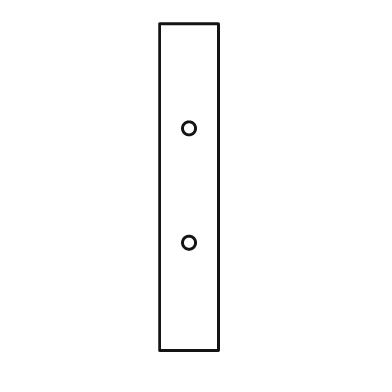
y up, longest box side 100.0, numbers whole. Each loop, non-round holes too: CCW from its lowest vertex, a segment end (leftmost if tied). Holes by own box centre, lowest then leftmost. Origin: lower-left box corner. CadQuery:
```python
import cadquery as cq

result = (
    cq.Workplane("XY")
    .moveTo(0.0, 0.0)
    .lineTo(18.0, 0.0)
    .lineTo(18.0, 100.0)
    .lineTo(0.0, 100.0)
    .close()
    .moveTo(9.0, 33.0)
    .circle(2.0)
    .moveTo(9.0, 68.0)
    .circle(2.0)
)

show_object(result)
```